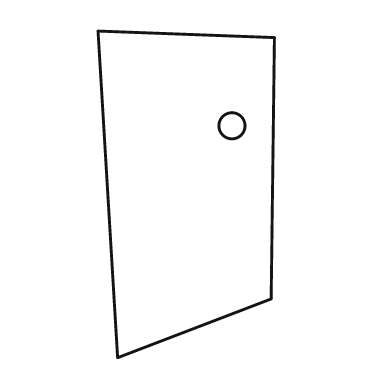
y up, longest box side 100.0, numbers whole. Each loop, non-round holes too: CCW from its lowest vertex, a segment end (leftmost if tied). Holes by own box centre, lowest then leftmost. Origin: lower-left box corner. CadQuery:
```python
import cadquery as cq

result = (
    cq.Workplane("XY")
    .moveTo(6.0, 0.0)
    .lineTo(53.0, 18.0)
    .lineTo(54.0, 98.0)
    .lineTo(0.0, 100.0)
    .close()
    .moveTo(41.0, 71.0)
    .circle(4.0)
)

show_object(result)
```